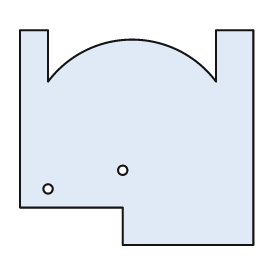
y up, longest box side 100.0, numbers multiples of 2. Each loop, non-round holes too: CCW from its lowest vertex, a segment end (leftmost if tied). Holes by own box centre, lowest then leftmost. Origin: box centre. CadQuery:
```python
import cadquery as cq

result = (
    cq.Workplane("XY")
    .moveTo(-6.0, -46.0)
    .lineTo(50.0, -46.0)
    .lineTo(50.0, 46.0)
    .lineTo(34.0, 46.0)
    .lineTo(34.0, 24.0)
    .threePointArc((-2.0, 42.0), (-38.0, 24.0))
    .lineTo(-38.0, 46.0)
    .lineTo(-50.0, 46.0)
    .lineTo(-50.0, -30.0)
    .lineTo(-6.0, -30.0)
    .close()
    .moveTo(-38.0, -22.0)
    .circle(2.0)
    .moveTo(-6.0, -14.0)
    .circle(2.0)
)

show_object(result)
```